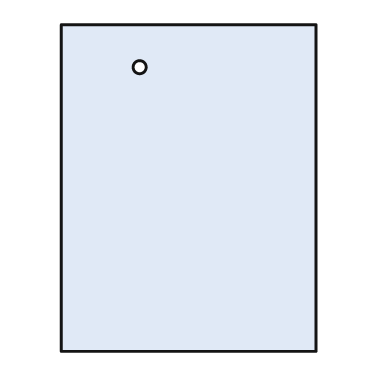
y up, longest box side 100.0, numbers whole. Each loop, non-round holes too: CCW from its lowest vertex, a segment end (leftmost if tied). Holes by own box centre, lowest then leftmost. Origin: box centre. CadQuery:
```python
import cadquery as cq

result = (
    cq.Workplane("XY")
    .moveTo(-39.0, -50.0)
    .lineTo(39.0, -50.0)
    .lineTo(39.0, 50.0)
    .lineTo(-39.0, 50.0)
    .close()
    .moveTo(-15.0, 37.0)
    .circle(2.0)
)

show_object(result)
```